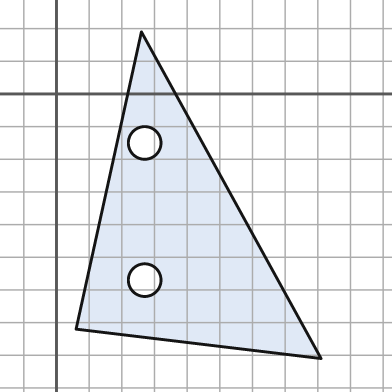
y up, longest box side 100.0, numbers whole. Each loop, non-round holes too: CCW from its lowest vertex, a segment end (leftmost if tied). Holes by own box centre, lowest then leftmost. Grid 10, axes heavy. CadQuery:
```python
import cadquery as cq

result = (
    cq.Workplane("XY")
    .moveTo(81.0, -81.0)
    .lineTo(26.0, 19.0)
    .lineTo(6.0, -72.0)
    .close()
    .moveTo(27.0, -57.0)
    .circle(5.0)
    .moveTo(27.0, -15.0)
    .circle(5.0)
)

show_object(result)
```